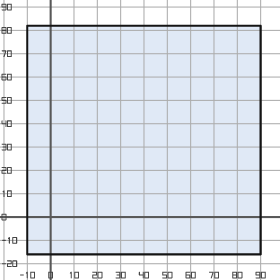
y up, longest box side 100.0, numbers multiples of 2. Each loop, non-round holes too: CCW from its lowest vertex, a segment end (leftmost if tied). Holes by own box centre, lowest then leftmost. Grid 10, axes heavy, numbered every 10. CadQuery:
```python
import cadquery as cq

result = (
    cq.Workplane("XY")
    .moveTo(-10.0, -16.0)
    .lineTo(90.0, -16.0)
    .lineTo(90.0, 82.0)
    .lineTo(-10.0, 82.0)
    .close()
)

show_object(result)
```